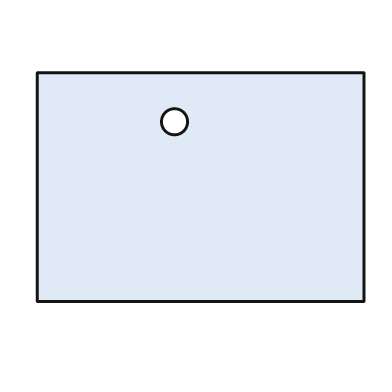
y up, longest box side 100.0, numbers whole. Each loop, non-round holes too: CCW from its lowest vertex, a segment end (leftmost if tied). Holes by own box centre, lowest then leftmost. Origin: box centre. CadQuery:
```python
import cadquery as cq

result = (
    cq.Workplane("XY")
    .moveTo(-50.0, -35.0)
    .lineTo(50.0, -35.0)
    .lineTo(50.0, 35.0)
    .lineTo(-50.0, 35.0)
    .close()
    .moveTo(-8.0, 20.0)
    .circle(4.0)
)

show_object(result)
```